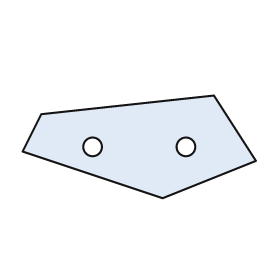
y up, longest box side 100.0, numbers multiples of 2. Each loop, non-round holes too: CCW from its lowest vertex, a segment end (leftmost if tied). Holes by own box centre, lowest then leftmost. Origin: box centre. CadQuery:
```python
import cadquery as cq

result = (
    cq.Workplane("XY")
    .moveTo(10.0, -22.0)
    .lineTo(50.0, -6.0)
    .lineTo(32.0, 22.0)
    .lineTo(-42.0, 14.0)
    .lineTo(-50.0, -2.0)
    .close()
    .moveTo(-20.0, 0.0)
    .circle(4.0)
    .moveTo(20.0, 0.0)
    .circle(4.0)
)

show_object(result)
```